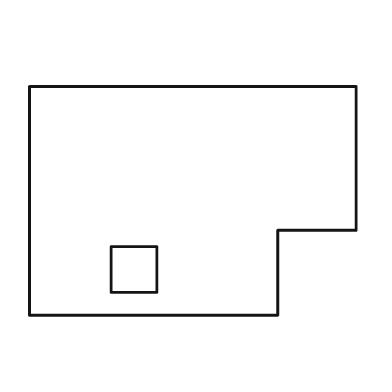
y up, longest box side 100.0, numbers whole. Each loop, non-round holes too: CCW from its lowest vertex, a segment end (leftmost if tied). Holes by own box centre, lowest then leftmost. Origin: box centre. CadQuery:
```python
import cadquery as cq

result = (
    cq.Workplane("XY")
    .moveTo(-50.0, -35.0)
    .lineTo(26.0, -35.0)
    .lineTo(26.0, -9.0)
    .lineTo(50.0, -9.0)
    .lineTo(50.0, 35.0)
    .lineTo(-50.0, 35.0)
    .close()
    .moveTo(-25.0, -28.0)
    .lineTo(-11.0, -28.0)
    .lineTo(-11.0, -14.0)
    .lineTo(-25.0, -14.0)
    .close()
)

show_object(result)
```